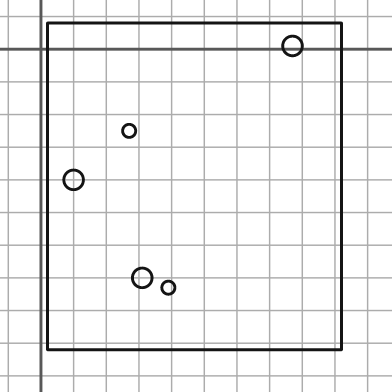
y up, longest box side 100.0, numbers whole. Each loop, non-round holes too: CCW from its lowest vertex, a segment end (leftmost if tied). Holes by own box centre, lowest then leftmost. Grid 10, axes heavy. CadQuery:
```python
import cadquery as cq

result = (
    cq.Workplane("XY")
    .moveTo(2.0, -92.0)
    .lineTo(92.0, -92.0)
    .lineTo(92.0, 8.0)
    .lineTo(2.0, 8.0)
    .close()
    .moveTo(39.0, -73.0)
    .circle(2.0)
    .moveTo(31.0, -70.0)
    .circle(3.0)
    .moveTo(10.0, -40.0)
    .circle(3.0)
    .moveTo(27.0, -25.0)
    .circle(2.0)
    .moveTo(77.0, 1.0)
    .circle(3.0)
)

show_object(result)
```